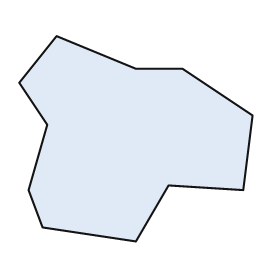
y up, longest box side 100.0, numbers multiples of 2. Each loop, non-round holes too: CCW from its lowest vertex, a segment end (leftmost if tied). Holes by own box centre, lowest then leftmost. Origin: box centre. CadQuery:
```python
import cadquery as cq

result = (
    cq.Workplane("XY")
    .moveTo(0.0, -44.0)
    .lineTo(14.0, -20.0)
    .lineTo(46.0, -22.0)
    .lineTo(50.0, 10.0)
    .lineTo(20.0, 30.0)
    .lineTo(0.0, 30.0)
    .lineTo(-34.0, 44.0)
    .lineTo(-50.0, 24.0)
    .lineTo(-38.0, 6.0)
    .lineTo(-46.0, -22.0)
    .lineTo(-40.0, -38.0)
    .close()
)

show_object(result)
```